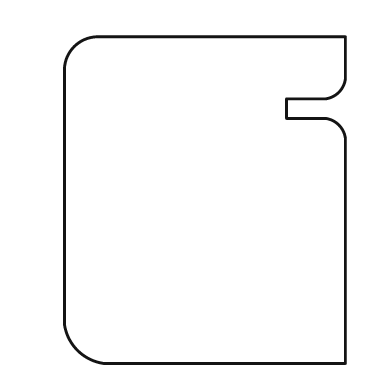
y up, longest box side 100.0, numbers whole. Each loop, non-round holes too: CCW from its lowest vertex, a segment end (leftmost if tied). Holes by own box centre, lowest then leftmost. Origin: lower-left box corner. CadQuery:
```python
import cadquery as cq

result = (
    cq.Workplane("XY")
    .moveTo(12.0, 0.0)
    .lineTo(86.0, 0.0)
    .lineTo(86.0, 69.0)
    .threePointArc((84.0, 73.0), (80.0, 75.0))
    .lineTo(68.0, 75.0)
    .lineTo(68.0, 81.0)
    .lineTo(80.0, 81.0)
    .threePointArc((84.0, 83.0), (86.0, 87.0))
    .lineTo(86.0, 100.0)
    .lineTo(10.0, 100.0)
    .threePointArc((3.0, 97.0), (0.0, 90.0))
    .lineTo(0.0, 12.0)
    .threePointArc((4.0, 4.0), (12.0, 0.0))
    .close()
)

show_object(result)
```